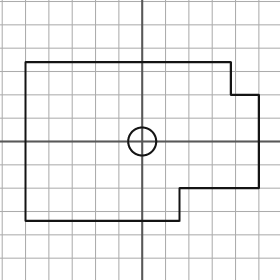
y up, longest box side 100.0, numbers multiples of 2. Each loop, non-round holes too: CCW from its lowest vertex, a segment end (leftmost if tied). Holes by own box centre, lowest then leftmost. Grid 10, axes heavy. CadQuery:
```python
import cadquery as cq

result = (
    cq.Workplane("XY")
    .moveTo(-50.0, -34.0)
    .lineTo(16.0, -34.0)
    .lineTo(16.0, -20.0)
    .lineTo(50.0, -20.0)
    .lineTo(50.0, 20.0)
    .lineTo(38.0, 20.0)
    .lineTo(38.0, 34.0)
    .lineTo(-50.0, 34.0)
    .close()
    .moveTo(0.0, 0.0)
    .circle(6.0)
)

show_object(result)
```